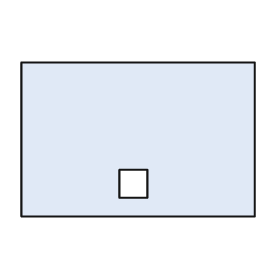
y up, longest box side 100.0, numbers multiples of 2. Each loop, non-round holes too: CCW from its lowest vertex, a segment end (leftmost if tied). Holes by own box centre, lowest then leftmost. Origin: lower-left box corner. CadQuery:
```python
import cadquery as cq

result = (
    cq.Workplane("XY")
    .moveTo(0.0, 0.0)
    .lineTo(100.0, 0.0)
    .lineTo(100.0, 66.0)
    .lineTo(0.0, 66.0)
    .close()
    .moveTo(42.0, 8.0)
    .lineTo(54.0, 8.0)
    .lineTo(54.0, 20.0)
    .lineTo(42.0, 20.0)
    .close()
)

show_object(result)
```